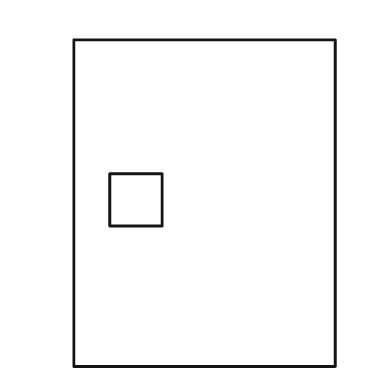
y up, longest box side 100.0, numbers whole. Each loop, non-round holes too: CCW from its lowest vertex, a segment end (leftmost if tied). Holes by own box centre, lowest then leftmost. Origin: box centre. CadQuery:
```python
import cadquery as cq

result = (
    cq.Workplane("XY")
    .moveTo(-40.0, -50.0)
    .lineTo(40.0, -50.0)
    .lineTo(40.0, 50.0)
    .lineTo(-40.0, 50.0)
    .close()
    .moveTo(-29.0, -7.0)
    .lineTo(-13.0, -7.0)
    .lineTo(-13.0, 9.0)
    .lineTo(-29.0, 9.0)
    .close()
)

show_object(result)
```